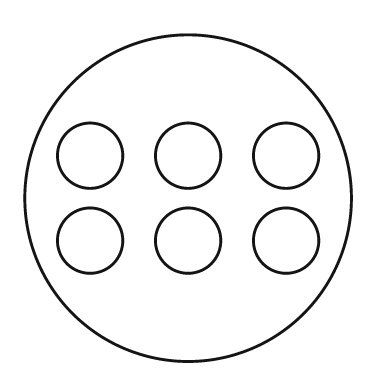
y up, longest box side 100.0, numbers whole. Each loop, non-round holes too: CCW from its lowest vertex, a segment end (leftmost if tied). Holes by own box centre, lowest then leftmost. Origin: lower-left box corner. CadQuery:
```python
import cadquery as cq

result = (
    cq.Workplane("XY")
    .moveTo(50.0, 50.0)
    .circle(50.0)
    .moveTo(20.0, 37.0)
    .circle(10.0)
    .moveTo(50.0, 37.0)
    .circle(10.0)
    .moveTo(80.0, 37.0)
    .circle(10.0)
    .moveTo(20.0, 63.0)
    .circle(10.0)
    .moveTo(50.0, 63.0)
    .circle(10.0)
    .moveTo(80.0, 63.0)
    .circle(10.0)
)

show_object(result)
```